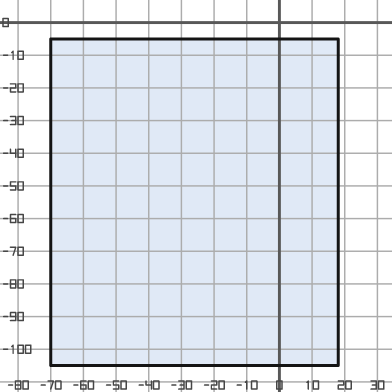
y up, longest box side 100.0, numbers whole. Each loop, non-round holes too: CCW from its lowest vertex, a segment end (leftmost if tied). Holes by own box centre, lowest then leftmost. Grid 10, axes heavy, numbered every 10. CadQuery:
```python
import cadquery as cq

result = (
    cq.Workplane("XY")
    .moveTo(-70.0, -105.0)
    .lineTo(18.0, -105.0)
    .lineTo(18.0, -5.0)
    .lineTo(-70.0, -5.0)
    .close()
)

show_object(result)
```